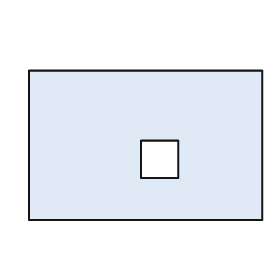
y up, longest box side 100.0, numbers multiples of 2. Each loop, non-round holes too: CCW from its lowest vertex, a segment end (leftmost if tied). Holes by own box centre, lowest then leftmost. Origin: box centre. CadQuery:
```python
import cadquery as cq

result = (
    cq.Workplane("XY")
    .moveTo(-50.0, -32.0)
    .lineTo(50.0, -32.0)
    .lineTo(50.0, 32.0)
    .lineTo(-50.0, 32.0)
    .close()
    .moveTo(-2.0, -14.0)
    .lineTo(14.0, -14.0)
    .lineTo(14.0, 2.0)
    .lineTo(-2.0, 2.0)
    .close()
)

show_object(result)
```